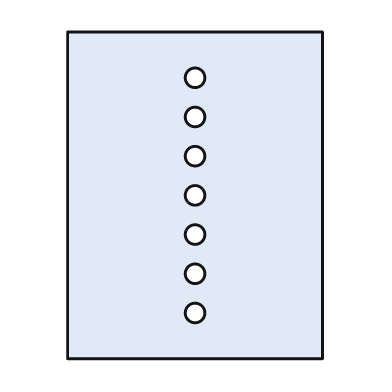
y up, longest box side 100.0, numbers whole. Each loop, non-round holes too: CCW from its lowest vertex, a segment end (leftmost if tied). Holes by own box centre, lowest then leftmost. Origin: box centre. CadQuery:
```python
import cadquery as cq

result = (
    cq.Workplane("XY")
    .moveTo(-39.0, -50.0)
    .lineTo(39.0, -50.0)
    .lineTo(39.0, 50.0)
    .lineTo(-39.0, 50.0)
    .close()
    .moveTo(0.0, -36.0)
    .circle(3.0)
    .moveTo(0.0, -24.0)
    .circle(3.0)
    .moveTo(0.0, -12.0)
    .circle(3.0)
    .moveTo(0.0, 0.0)
    .circle(3.0)
    .moveTo(0.0, 12.0)
    .circle(3.0)
    .moveTo(0.0, 24.0)
    .circle(3.0)
    .moveTo(0.0, 36.0)
    .circle(3.0)
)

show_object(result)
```